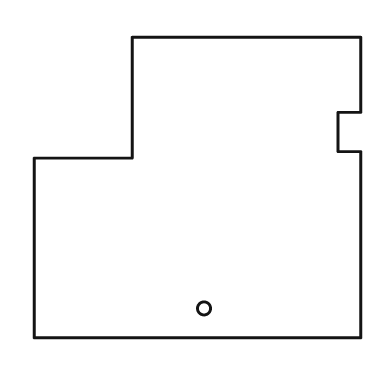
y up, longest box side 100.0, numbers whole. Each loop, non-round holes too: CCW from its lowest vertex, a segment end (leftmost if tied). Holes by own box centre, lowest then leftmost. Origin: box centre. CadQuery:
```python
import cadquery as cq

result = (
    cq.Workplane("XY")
    .moveTo(-50.0, -46.0)
    .lineTo(50.0, -46.0)
    .lineTo(50.0, 11.0)
    .lineTo(43.0, 11.0)
    .lineTo(43.0, 23.0)
    .lineTo(50.0, 23.0)
    .lineTo(50.0, 46.0)
    .lineTo(-20.0, 46.0)
    .lineTo(-20.0, 9.0)
    .lineTo(-50.0, 9.0)
    .close()
    .moveTo(2.0, -37.0)
    .circle(2.0)
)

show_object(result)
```